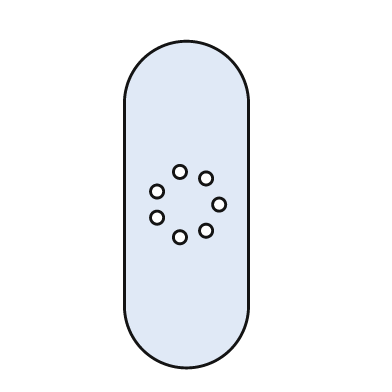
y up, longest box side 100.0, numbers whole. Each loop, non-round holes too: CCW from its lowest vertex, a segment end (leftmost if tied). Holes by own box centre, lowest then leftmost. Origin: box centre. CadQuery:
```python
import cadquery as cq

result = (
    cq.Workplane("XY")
    .moveTo(-19.0, -31.0)
    .threePointArc((0.0, -50.0), (19.0, -31.0))
    .lineTo(19.0, 31.0)
    .threePointArc((0.0, 50.0), (-19.0, 31.0))
    .close()
    .moveTo(-2.0, -10.0)
    .circle(2.0)
    .moveTo(6.0, -8.0)
    .circle(2.0)
    .moveTo(-9.0, -4.0)
    .circle(2.0)
    .moveTo(10.0, 0.0)
    .circle(2.0)
    .moveTo(-9.0, 4.0)
    .circle(2.0)
    .moveTo(6.0, 8.0)
    .circle(2.0)
    .moveTo(-2.0, 10.0)
    .circle(2.0)
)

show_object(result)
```